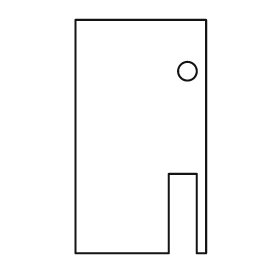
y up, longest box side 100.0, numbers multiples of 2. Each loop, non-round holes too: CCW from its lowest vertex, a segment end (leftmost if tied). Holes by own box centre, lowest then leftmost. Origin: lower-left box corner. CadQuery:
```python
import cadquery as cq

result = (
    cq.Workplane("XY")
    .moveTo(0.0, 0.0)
    .lineTo(40.0, 0.0)
    .lineTo(40.0, 34.0)
    .lineTo(52.0, 34.0)
    .lineTo(52.0, 0.0)
    .lineTo(56.0, 0.0)
    .lineTo(56.0, 100.0)
    .lineTo(0.0, 100.0)
    .close()
    .moveTo(48.0, 78.0)
    .circle(4.0)
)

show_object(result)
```